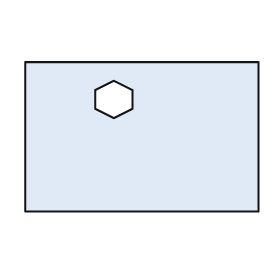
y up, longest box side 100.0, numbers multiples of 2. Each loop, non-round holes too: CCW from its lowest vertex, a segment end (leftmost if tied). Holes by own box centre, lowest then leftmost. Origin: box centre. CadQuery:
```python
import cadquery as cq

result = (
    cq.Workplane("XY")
    .moveTo(-50.0, -32.0)
    .lineTo(50.0, -32.0)
    .lineTo(50.0, 32.0)
    .lineTo(-50.0, 32.0)
    .close()
    .moveTo(-12.0, 8.0)
    .lineTo(-4.0, 12.0)
    .lineTo(-4.0, 20.0)
    .lineTo(-12.0, 24.0)
    .lineTo(-20.0, 20.0)
    .lineTo(-20.0, 12.0)
    .close()
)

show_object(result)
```